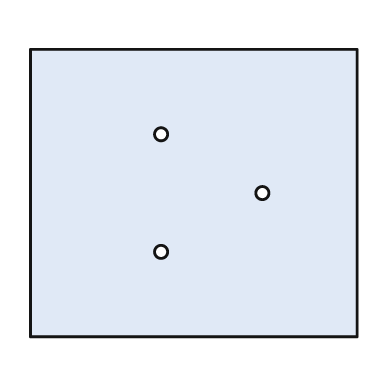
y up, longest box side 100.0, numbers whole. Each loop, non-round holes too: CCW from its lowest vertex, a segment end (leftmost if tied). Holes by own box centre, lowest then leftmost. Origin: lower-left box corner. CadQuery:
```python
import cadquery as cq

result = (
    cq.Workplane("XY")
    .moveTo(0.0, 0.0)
    .lineTo(100.0, 0.0)
    .lineTo(100.0, 88.0)
    .lineTo(0.0, 88.0)
    .close()
    .moveTo(40.0, 26.0)
    .circle(2.0)
    .moveTo(71.0, 44.0)
    .circle(2.0)
    .moveTo(40.0, 62.0)
    .circle(2.0)
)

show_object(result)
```